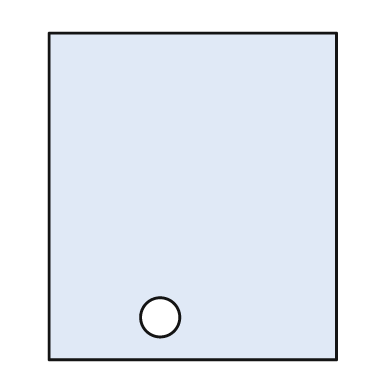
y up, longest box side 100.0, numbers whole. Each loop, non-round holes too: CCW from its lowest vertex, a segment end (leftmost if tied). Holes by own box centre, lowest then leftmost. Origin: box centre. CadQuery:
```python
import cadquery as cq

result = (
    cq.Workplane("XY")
    .moveTo(-44.0, -50.0)
    .lineTo(44.0, -50.0)
    .lineTo(44.0, 50.0)
    .lineTo(-44.0, 50.0)
    .close()
    .moveTo(-10.0, -37.0)
    .circle(6.0)
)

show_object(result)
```